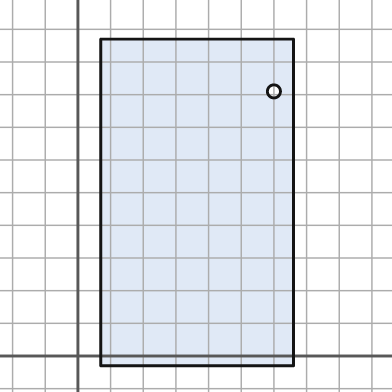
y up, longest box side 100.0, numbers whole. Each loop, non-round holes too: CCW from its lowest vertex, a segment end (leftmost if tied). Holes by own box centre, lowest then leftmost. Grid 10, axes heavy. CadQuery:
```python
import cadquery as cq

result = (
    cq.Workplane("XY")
    .moveTo(7.0, -3.0)
    .lineTo(66.0, -3.0)
    .lineTo(66.0, 97.0)
    .lineTo(7.0, 97.0)
    .close()
    .moveTo(60.0, 81.0)
    .circle(2.0)
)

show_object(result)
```